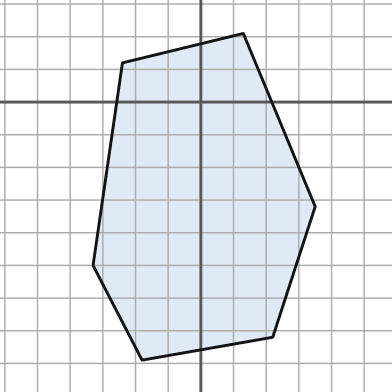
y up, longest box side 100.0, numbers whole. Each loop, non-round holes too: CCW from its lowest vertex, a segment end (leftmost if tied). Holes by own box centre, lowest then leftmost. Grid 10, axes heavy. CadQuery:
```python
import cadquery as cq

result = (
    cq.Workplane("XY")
    .moveTo(-18.0, -79.0)
    .lineTo(22.0, -72.0)
    .lineTo(35.0, -32.0)
    .lineTo(13.0, 21.0)
    .lineTo(-24.0, 12.0)
    .lineTo(-33.0, -50.0)
    .close()
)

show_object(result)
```